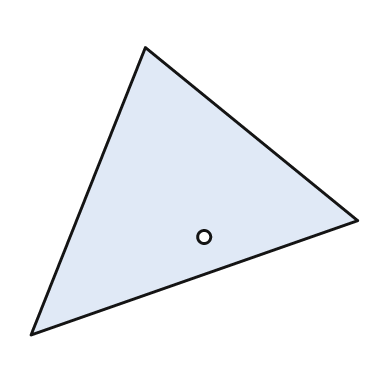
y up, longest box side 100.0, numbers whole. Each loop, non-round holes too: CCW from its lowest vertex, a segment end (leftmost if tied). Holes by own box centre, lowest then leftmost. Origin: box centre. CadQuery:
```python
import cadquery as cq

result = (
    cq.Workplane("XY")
    .moveTo(-50.0, -44.0)
    .lineTo(50.0, -9.0)
    .lineTo(-15.0, 44.0)
    .close()
    .moveTo(3.0, -14.0)
    .circle(2.0)
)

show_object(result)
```